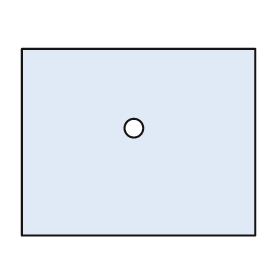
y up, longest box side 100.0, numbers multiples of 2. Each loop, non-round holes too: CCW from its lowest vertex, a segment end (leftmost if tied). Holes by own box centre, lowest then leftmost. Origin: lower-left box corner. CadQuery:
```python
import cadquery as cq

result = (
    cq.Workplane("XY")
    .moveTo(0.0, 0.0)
    .lineTo(100.0, 0.0)
    .lineTo(100.0, 80.0)
    .lineTo(0.0, 80.0)
    .close()
    .moveTo(48.0, 46.0)
    .circle(4.0)
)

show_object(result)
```